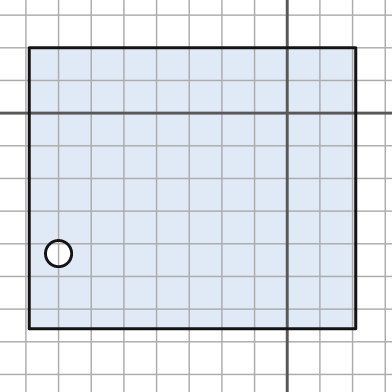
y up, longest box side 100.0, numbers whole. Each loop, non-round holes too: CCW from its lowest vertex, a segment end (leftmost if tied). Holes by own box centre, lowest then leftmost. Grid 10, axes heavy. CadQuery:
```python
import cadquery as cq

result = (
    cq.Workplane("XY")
    .moveTo(-79.0, -66.0)
    .lineTo(21.0, -66.0)
    .lineTo(21.0, 20.0)
    .lineTo(-79.0, 20.0)
    .close()
    .moveTo(-70.0, -43.0)
    .circle(4.0)
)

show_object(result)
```